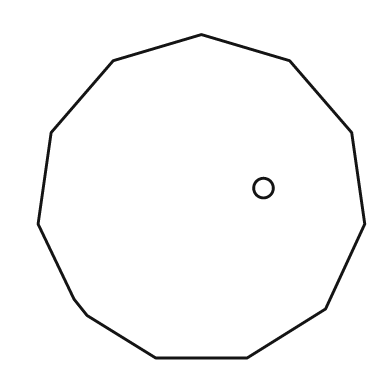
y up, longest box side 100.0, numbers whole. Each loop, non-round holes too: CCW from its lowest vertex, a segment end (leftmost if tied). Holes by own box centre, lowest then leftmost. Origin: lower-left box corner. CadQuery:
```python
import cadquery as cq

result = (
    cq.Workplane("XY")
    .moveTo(36.0, 0.0)
    .lineTo(64.0, 0.0)
    .lineTo(88.0, 15.0)
    .lineTo(100.0, 41.0)
    .lineTo(96.0, 69.0)
    .lineTo(77.0, 91.0)
    .lineTo(50.0, 99.0)
    .lineTo(23.0, 91.0)
    .lineTo(4.0, 69.0)
    .lineTo(0.0, 41.0)
    .lineTo(11.0, 18.0)
    .lineTo(15.0, 13.0)
    .close()
    .moveTo(69.0, 52.0)
    .circle(3.0)
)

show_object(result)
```